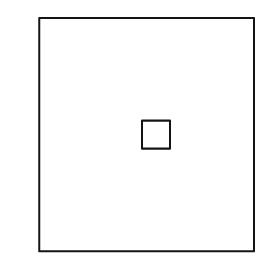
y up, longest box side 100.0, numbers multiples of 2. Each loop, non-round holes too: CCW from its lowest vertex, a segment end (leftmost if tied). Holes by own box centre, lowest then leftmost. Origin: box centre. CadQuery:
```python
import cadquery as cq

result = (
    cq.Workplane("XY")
    .moveTo(-46.0, -50.0)
    .lineTo(46.0, -50.0)
    .lineTo(46.0, 50.0)
    .lineTo(-46.0, 50.0)
    .close()
    .moveTo(-2.0, -6.0)
    .lineTo(10.0, -6.0)
    .lineTo(10.0, 6.0)
    .lineTo(-2.0, 6.0)
    .close()
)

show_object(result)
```